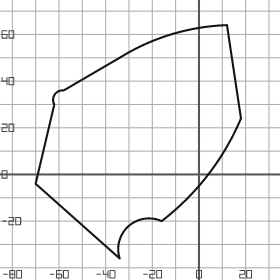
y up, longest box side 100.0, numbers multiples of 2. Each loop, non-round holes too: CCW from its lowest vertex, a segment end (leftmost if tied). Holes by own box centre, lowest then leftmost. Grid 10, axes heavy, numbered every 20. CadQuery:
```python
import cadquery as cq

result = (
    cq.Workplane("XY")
    .moveTo(-34.0, -36.0)
    .threePointArc((-30.0, -22.0), (-16.0, -20.0))
    .threePointArc((4.0, 0.0), (18.0, 24.0))
    .lineTo(12.0, 64.0)
    .threePointArc((-12.0, 60.0), (-34.0, 50.0))
    .lineTo(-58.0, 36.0)
    .threePointArc((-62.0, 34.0), (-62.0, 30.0))
    .lineTo(-70.0, -4.0)
    .close()
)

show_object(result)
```